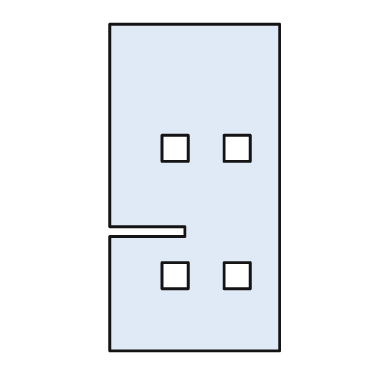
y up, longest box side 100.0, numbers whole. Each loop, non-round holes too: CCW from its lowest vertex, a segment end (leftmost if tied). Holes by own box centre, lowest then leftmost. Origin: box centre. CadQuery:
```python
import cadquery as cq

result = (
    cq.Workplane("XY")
    .moveTo(-26.0, -50.0)
    .lineTo(26.0, -50.0)
    .lineTo(26.0, 50.0)
    .lineTo(-26.0, 50.0)
    .lineTo(-26.0, -12.0)
    .lineTo(-3.0, -12.0)
    .lineTo(-3.0, -15.0)
    .lineTo(-26.0, -15.0)
    .close()
    .moveTo(-10.0, -31.0)
    .lineTo(-2.0, -31.0)
    .lineTo(-2.0, -23.0)
    .lineTo(-10.0, -23.0)
    .close()
    .moveTo(9.0, -31.0)
    .lineTo(17.0, -31.0)
    .lineTo(17.0, -23.0)
    .lineTo(9.0, -23.0)
    .close()
    .moveTo(-10.0, 8.0)
    .lineTo(-2.0, 8.0)
    .lineTo(-2.0, 16.0)
    .lineTo(-10.0, 16.0)
    .close()
    .moveTo(9.0, 8.0)
    .lineTo(17.0, 8.0)
    .lineTo(17.0, 16.0)
    .lineTo(9.0, 16.0)
    .close()
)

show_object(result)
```